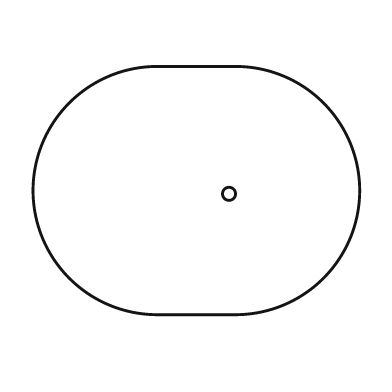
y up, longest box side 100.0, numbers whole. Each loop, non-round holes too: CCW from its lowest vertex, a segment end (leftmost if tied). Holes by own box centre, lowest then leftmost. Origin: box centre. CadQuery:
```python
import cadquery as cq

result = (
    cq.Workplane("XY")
    .moveTo(-12.0, -38.0)
    .lineTo(12.0, -38.0)
    .threePointArc((50.0, 0.0), (12.0, 38.0))
    .lineTo(-12.0, 38.0)
    .threePointArc((-50.0, 0.0), (-12.0, -38.0))
    .close()
    .moveTo(10.0, -1.0)
    .circle(2.0)
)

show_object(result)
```